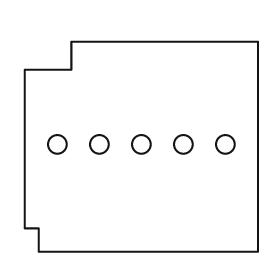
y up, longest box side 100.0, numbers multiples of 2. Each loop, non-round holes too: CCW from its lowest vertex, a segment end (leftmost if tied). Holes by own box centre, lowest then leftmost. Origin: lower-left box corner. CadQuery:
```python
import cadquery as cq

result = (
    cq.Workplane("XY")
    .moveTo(6.0, 0.0)
    .lineTo(100.0, 0.0)
    .lineTo(100.0, 90.0)
    .lineTo(20.0, 90.0)
    .lineTo(20.0, 78.0)
    .lineTo(0.0, 78.0)
    .lineTo(0.0, 10.0)
    .lineTo(6.0, 10.0)
    .close()
    .moveTo(14.0, 46.0)
    .circle(4.0)
    .moveTo(32.0, 46.0)
    .circle(4.0)
    .moveTo(50.0, 46.0)
    .circle(4.0)
    .moveTo(68.0, 46.0)
    .circle(4.0)
    .moveTo(86.0, 46.0)
    .circle(4.0)
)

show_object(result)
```